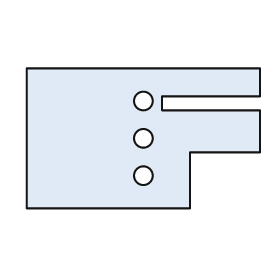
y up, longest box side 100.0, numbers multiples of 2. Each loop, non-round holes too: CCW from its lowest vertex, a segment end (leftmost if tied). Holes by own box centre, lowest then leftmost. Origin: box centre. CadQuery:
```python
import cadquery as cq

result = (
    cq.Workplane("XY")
    .moveTo(-50.0, -30.0)
    .lineTo(20.0, -30.0)
    .lineTo(20.0, -6.0)
    .lineTo(50.0, -6.0)
    .lineTo(50.0, 12.0)
    .lineTo(8.0, 12.0)
    .lineTo(8.0, 18.0)
    .lineTo(50.0, 18.0)
    .lineTo(50.0, 30.0)
    .lineTo(-50.0, 30.0)
    .close()
    .moveTo(0.0, -16.0)
    .circle(4.0)
    .moveTo(0.0, 0.0)
    .circle(4.0)
    .moveTo(0.0, 16.0)
    .circle(4.0)
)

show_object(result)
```